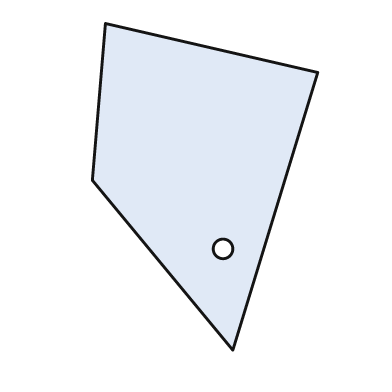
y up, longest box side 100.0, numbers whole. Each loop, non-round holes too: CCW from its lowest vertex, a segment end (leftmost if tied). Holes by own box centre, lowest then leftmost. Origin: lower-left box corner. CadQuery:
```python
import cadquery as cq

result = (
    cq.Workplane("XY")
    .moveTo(43.0, 0.0)
    .lineTo(69.0, 85.0)
    .lineTo(4.0, 100.0)
    .lineTo(0.0, 52.0)
    .close()
    .moveTo(40.0, 31.0)
    .circle(3.0)
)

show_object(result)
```